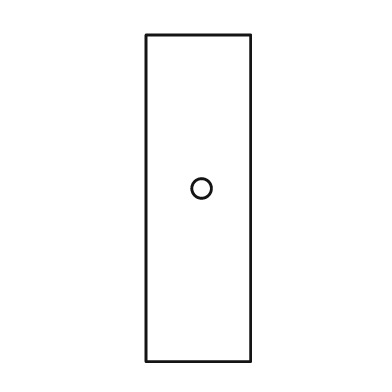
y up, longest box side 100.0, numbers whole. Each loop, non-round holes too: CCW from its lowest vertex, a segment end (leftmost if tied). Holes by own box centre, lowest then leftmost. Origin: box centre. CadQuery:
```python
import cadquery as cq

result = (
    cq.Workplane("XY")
    .moveTo(-16.0, -50.0)
    .lineTo(16.0, -50.0)
    .lineTo(16.0, 50.0)
    .lineTo(-16.0, 50.0)
    .close()
    .moveTo(1.0, 3.0)
    .circle(3.0)
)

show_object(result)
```